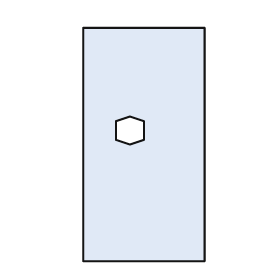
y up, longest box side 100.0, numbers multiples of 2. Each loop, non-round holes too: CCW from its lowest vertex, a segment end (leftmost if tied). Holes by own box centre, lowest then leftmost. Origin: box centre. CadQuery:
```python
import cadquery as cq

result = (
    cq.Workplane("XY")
    .moveTo(-26.0, -50.0)
    .lineTo(26.0, -50.0)
    .lineTo(26.0, 50.0)
    .lineTo(-26.0, 50.0)
    .close()
    .moveTo(-6.0, 0.0)
    .lineTo(0.0, 2.0)
    .lineTo(0.0, 10.0)
    .lineTo(-6.0, 12.0)
    .lineTo(-12.0, 10.0)
    .lineTo(-12.0, 2.0)
    .close()
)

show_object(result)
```